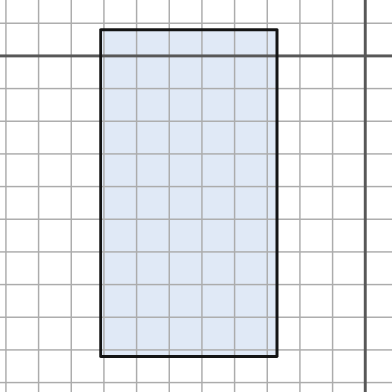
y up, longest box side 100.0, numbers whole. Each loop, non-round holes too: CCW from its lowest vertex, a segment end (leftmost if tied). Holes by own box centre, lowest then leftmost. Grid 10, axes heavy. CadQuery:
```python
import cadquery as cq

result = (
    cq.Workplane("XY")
    .moveTo(-81.0, -92.0)
    .lineTo(-27.0, -92.0)
    .lineTo(-27.0, 8.0)
    .lineTo(-81.0, 8.0)
    .close()
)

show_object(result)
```